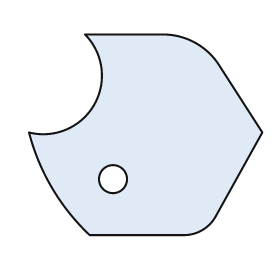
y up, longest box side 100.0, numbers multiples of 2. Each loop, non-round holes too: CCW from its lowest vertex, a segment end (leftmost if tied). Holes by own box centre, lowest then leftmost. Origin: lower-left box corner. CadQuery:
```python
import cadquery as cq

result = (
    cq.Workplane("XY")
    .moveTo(26.0, 0.0)
    .lineTo(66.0, 0.0)
    .threePointArc((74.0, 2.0), (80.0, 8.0))
    .lineTo(100.0, 44.0)
    .lineTo(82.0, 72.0)
    .threePointArc((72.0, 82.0), (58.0, 86.0))
    .lineTo(24.0, 86.0)
    .threePointArc((28.0, 56.0), (0.0, 44.0))
    .threePointArc((10.0, 20.0), (26.0, 0.0))
    .close()
    .moveTo(36.0, 24.0)
    .circle(6.0)
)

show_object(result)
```